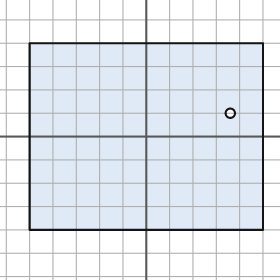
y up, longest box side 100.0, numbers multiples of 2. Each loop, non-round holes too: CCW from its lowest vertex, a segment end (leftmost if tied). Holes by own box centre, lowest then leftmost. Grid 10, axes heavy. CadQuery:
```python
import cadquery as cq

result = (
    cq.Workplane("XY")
    .moveTo(-50.0, -40.0)
    .lineTo(50.0, -40.0)
    .lineTo(50.0, 40.0)
    .lineTo(-50.0, 40.0)
    .close()
    .moveTo(36.0, 10.0)
    .circle(2.0)
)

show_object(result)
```